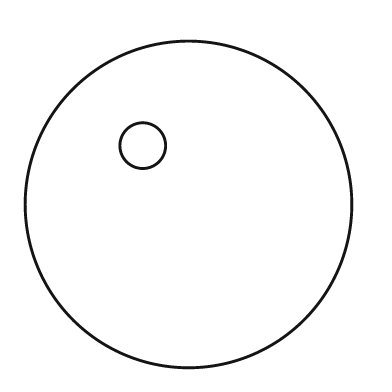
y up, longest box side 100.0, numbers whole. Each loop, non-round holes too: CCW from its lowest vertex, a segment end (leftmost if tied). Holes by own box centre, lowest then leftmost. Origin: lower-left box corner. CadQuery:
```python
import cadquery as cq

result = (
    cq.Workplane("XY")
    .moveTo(50.0, 50.0)
    .circle(50.0)
    .moveTo(36.0, 68.0)
    .circle(7.0)
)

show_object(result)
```